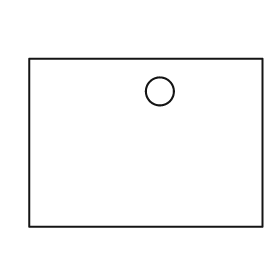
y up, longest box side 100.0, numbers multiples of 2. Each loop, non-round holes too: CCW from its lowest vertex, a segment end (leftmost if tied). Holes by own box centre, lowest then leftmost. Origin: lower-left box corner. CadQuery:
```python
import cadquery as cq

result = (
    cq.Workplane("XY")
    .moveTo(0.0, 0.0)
    .lineTo(100.0, 0.0)
    .lineTo(100.0, 72.0)
    .lineTo(0.0, 72.0)
    .close()
    .moveTo(56.0, 58.0)
    .circle(6.0)
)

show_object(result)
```